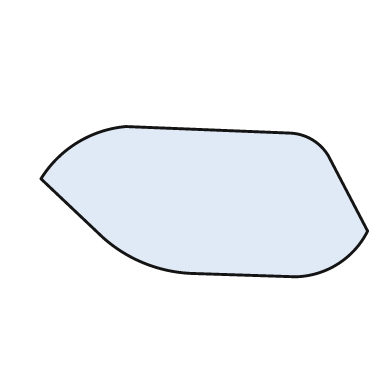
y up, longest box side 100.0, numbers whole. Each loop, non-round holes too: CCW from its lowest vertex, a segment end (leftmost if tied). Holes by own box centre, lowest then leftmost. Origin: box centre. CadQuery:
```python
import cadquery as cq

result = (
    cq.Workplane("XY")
    .moveTo(28.0, -23.0)
    .threePointArc((41.0, -19.0), (50.0, -9.0))
    .lineTo(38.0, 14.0)
    .threePointArc((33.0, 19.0), (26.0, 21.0))
    .lineTo(-24.0, 23.0)
    .threePointArc((-39.0, 18.0), (-50.0, 7.0))
    .lineTo(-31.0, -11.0)
    .threePointArc((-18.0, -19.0), (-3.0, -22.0))
    .close()
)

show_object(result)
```